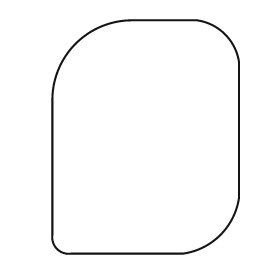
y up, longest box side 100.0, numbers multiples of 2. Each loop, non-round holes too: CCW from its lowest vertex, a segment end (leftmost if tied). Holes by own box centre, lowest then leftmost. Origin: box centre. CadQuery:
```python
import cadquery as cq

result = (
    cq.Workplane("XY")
    .moveTo(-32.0, -50.0)
    .lineTo(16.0, -50.0)
    .threePointArc((32.0, -42.0), (40.0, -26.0))
    .lineTo(40.0, 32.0)
    .threePointArc((34.0, 44.0), (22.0, 50.0))
    .lineTo(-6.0, 50.0)
    .threePointArc((-30.0, 40.0), (-40.0, 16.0))
    .lineTo(-40.0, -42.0)
    .threePointArc((-38.0, -48.0), (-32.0, -50.0))
    .close()
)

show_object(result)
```